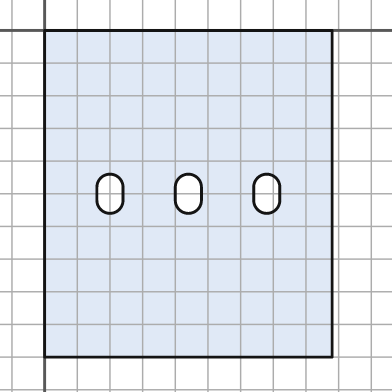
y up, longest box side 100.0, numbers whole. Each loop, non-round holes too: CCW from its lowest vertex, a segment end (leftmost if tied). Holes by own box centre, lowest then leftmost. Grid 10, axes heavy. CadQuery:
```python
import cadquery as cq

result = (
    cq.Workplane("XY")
    .moveTo(0.0, -100.0)
    .lineTo(88.0, -100.0)
    .lineTo(88.0, 0.0)
    .lineTo(0.0, 0.0)
    .close()
    .moveTo(16.0, -52.0)
    .threePointArc((20.0, -56.0), (24.0, -52.0))
    .lineTo(24.0, -48.0)
    .threePointArc((20.0, -44.0), (16.0, -48.0))
    .close()
    .moveTo(40.0, -52.0)
    .threePointArc((44.0, -56.0), (48.0, -52.0))
    .lineTo(48.0, -48.0)
    .threePointArc((44.0, -44.0), (40.0, -48.0))
    .close()
    .moveTo(64.0, -52.0)
    .threePointArc((68.0, -56.0), (72.0, -52.0))
    .lineTo(72.0, -48.0)
    .threePointArc((68.0, -44.0), (64.0, -48.0))
    .close()
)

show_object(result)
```